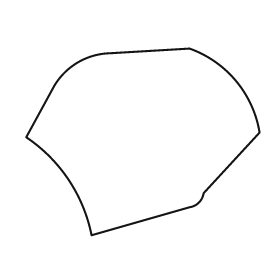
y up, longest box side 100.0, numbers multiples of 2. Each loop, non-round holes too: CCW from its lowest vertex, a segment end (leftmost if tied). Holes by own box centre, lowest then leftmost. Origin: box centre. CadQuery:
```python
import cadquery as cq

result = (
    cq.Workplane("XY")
    .moveTo(-22.0, -40.0)
    .lineTo(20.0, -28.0)
    .threePointArc((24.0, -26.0), (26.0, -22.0))
    .lineTo(50.0, 4.0)
    .threePointArc((40.0, 26.0), (20.0, 40.0))
    .lineTo(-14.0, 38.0)
    .threePointArc((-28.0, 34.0), (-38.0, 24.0))
    .lineTo(-50.0, 2.0)
    .threePointArc((-32.0, -16.0), (-22.0, -40.0))
    .close()
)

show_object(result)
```